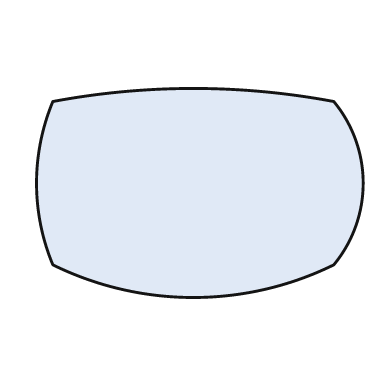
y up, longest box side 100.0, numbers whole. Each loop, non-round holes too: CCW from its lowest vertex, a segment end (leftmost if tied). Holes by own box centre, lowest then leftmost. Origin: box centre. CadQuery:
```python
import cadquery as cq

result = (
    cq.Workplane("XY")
    .moveTo(-45.0, -22.0)
    .threePointArc((-2.0, -32.0), (41.0, -22.0))
    .threePointArc((50.0, 3.0), (41.0, 28.0))
    .threePointArc((-2.0, 32.0), (-45.0, 28.0))
    .threePointArc((-50.0, 3.0), (-45.0, -22.0))
    .close()
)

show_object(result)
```